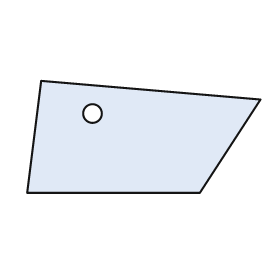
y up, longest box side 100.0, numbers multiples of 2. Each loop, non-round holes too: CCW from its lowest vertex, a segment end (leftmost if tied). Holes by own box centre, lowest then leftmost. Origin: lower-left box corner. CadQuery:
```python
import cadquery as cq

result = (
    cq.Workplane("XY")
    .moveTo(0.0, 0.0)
    .lineTo(74.0, 0.0)
    .lineTo(100.0, 40.0)
    .lineTo(6.0, 48.0)
    .close()
    .moveTo(28.0, 34.0)
    .circle(4.0)
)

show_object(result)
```